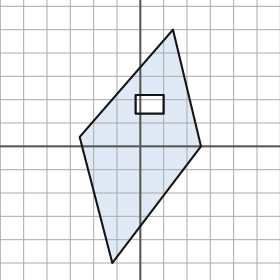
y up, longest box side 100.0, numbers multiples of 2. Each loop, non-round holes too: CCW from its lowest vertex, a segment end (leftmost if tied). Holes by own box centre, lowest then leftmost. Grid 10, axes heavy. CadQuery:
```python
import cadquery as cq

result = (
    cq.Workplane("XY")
    .moveTo(-12.0, -50.0)
    .lineTo(26.0, 0.0)
    .lineTo(14.0, 50.0)
    .lineTo(-26.0, 4.0)
    .close()
    .moveTo(-2.0, 14.0)
    .lineTo(10.0, 14.0)
    .lineTo(10.0, 22.0)
    .lineTo(-2.0, 22.0)
    .close()
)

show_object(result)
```